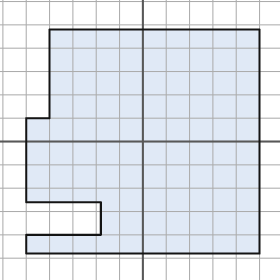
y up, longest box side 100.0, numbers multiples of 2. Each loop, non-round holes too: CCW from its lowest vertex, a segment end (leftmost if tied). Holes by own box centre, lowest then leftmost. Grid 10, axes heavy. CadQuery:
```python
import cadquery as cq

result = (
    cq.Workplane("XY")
    .moveTo(-50.0, -48.0)
    .lineTo(50.0, -48.0)
    .lineTo(50.0, 48.0)
    .lineTo(-40.0, 48.0)
    .lineTo(-40.0, 10.0)
    .lineTo(-50.0, 10.0)
    .lineTo(-50.0, -26.0)
    .lineTo(-18.0, -26.0)
    .lineTo(-18.0, -40.0)
    .lineTo(-50.0, -40.0)
    .close()
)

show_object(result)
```